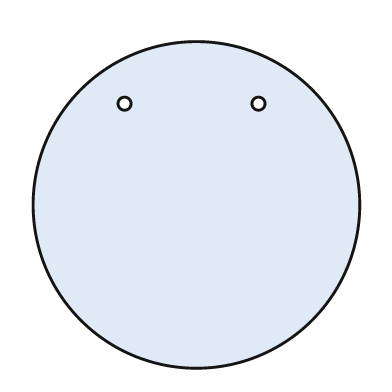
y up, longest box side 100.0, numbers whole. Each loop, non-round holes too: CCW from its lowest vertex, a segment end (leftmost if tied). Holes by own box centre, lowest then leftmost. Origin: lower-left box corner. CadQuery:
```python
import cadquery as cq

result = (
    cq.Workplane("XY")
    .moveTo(50.0, 50.0)
    .circle(50.0)
    .moveTo(28.0, 81.0)
    .circle(2.0)
    .moveTo(69.0, 81.0)
    .circle(2.0)
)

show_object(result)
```